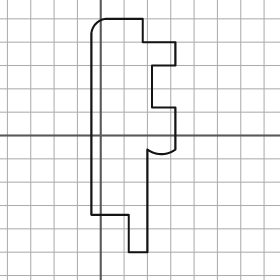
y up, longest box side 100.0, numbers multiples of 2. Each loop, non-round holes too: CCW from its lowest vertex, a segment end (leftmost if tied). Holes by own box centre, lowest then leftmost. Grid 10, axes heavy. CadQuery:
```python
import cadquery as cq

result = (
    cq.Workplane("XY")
    .moveTo(12.0, -50.0)
    .lineTo(20.0, -50.0)
    .lineTo(20.0, -6.0)
    .threePointArc((26.0, -8.0), (32.0, -6.0))
    .lineTo(32.0, 12.0)
    .lineTo(22.0, 12.0)
    .lineTo(22.0, 30.0)
    .lineTo(32.0, 30.0)
    .lineTo(32.0, 40.0)
    .lineTo(18.0, 40.0)
    .lineTo(18.0, 50.0)
    .lineTo(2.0, 50.0)
    .threePointArc((-2.0, 48.0), (-4.0, 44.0))
    .lineTo(-4.0, -34.0)
    .lineTo(12.0, -34.0)
    .close()
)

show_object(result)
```